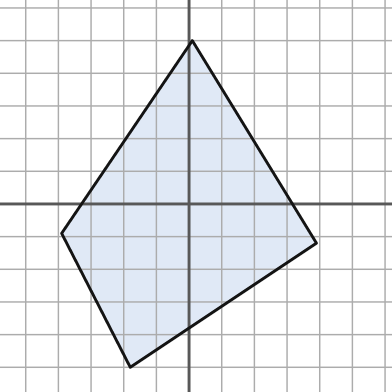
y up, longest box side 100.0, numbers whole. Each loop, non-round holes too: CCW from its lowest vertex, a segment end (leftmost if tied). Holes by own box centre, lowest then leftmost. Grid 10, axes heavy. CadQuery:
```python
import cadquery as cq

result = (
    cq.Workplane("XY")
    .moveTo(-18.0, -50.0)
    .lineTo(39.0, -12.0)
    .lineTo(1.0, 50.0)
    .lineTo(-39.0, -9.0)
    .close()
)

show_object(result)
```